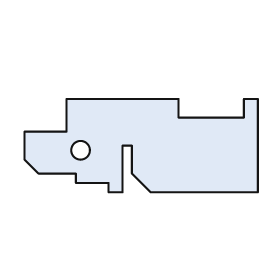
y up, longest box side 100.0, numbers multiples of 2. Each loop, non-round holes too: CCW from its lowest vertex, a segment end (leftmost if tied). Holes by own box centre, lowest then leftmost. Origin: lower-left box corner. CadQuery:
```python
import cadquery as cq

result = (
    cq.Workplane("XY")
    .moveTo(36.0, 0.0)
    .lineTo(42.0, 0.0)
    .lineTo(42.0, 20.0)
    .lineTo(46.0, 20.0)
    .lineTo(46.0, 8.0)
    .lineTo(54.0, 0.0)
    .lineTo(100.0, 0.0)
    .lineTo(100.0, 40.0)
    .lineTo(94.0, 40.0)
    .lineTo(94.0, 32.0)
    .lineTo(66.0, 32.0)
    .lineTo(66.0, 40.0)
    .lineTo(18.0, 40.0)
    .lineTo(18.0, 26.0)
    .lineTo(0.0, 26.0)
    .lineTo(0.0, 14.0)
    .lineTo(6.0, 8.0)
    .lineTo(22.0, 8.0)
    .lineTo(22.0, 4.0)
    .lineTo(36.0, 4.0)
    .close()
    .moveTo(24.0, 18.0)
    .circle(4.0)
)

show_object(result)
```